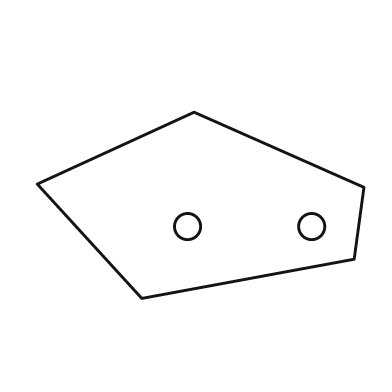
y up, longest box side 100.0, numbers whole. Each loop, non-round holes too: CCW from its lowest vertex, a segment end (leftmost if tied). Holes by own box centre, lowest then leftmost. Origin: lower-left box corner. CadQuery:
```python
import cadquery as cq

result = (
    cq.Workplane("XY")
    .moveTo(32.0, 0.0)
    .lineTo(97.0, 12.0)
    .lineTo(100.0, 34.0)
    .lineTo(48.0, 57.0)
    .lineTo(0.0, 35.0)
    .close()
    .moveTo(46.0, 22.0)
    .circle(4.0)
    .moveTo(84.0, 22.0)
    .circle(4.0)
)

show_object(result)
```